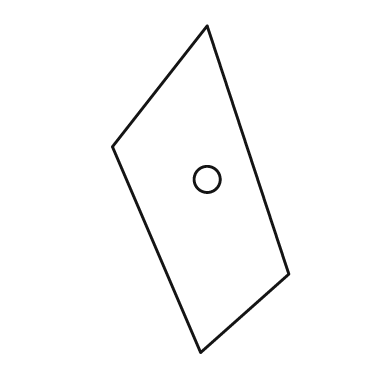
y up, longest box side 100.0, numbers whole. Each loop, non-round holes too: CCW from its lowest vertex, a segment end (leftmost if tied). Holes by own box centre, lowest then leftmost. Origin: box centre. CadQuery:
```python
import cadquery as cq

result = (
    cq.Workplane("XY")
    .moveTo(0.0, -50.0)
    .lineTo(27.0, -26.0)
    .lineTo(2.0, 50.0)
    .lineTo(-27.0, 13.0)
    .close()
    .moveTo(2.0, 3.0)
    .circle(4.0)
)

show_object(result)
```